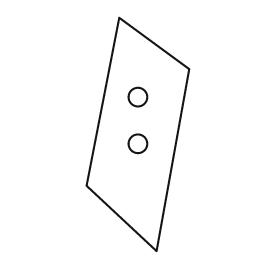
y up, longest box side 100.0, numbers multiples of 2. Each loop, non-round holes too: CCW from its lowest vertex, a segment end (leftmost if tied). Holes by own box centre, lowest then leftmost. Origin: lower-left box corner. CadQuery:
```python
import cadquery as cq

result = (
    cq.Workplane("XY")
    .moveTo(30.0, 0.0)
    .lineTo(44.0, 78.0)
    .lineTo(14.0, 100.0)
    .lineTo(0.0, 28.0)
    .close()
    .moveTo(22.0, 46.0)
    .circle(4.0)
    .moveTo(22.0, 66.0)
    .circle(4.0)
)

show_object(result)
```